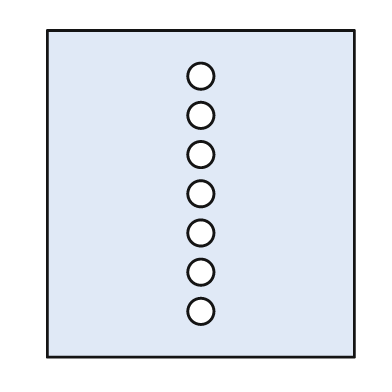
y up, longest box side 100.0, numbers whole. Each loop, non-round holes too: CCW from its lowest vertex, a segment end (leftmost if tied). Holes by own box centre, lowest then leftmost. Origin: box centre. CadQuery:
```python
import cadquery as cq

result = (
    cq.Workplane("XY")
    .moveTo(-47.0, -50.0)
    .lineTo(47.0, -50.0)
    .lineTo(47.0, 50.0)
    .lineTo(-47.0, 50.0)
    .close()
    .moveTo(0.0, -36.0)
    .circle(4.0)
    .moveTo(0.0, -24.0)
    .circle(4.0)
    .moveTo(0.0, -12.0)
    .circle(4.0)
    .moveTo(0.0, 0.0)
    .circle(4.0)
    .moveTo(0.0, 12.0)
    .circle(4.0)
    .moveTo(0.0, 24.0)
    .circle(4.0)
    .moveTo(0.0, 36.0)
    .circle(4.0)
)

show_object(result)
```